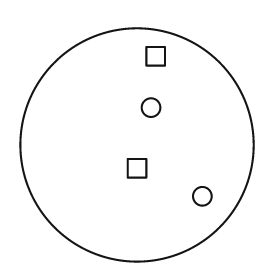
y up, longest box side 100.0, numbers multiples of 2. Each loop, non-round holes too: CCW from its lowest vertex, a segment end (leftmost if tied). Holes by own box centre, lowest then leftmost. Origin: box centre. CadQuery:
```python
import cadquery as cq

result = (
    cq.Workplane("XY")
    .moveTo(0.0, 0.0)
    .circle(50.0)
    .moveTo(28.0, -22.0)
    .circle(4.0)
    .moveTo(-4.0, -14.0)
    .lineTo(4.0, -14.0)
    .lineTo(4.0, -6.0)
    .lineTo(-4.0, -6.0)
    .close()
    .moveTo(6.0, 16.0)
    .circle(4.0)
    .moveTo(4.0, 34.0)
    .lineTo(12.0, 34.0)
    .lineTo(12.0, 42.0)
    .lineTo(4.0, 42.0)
    .close()
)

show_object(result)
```